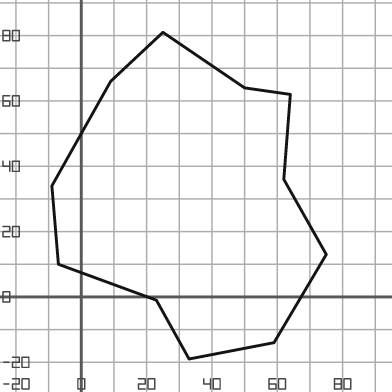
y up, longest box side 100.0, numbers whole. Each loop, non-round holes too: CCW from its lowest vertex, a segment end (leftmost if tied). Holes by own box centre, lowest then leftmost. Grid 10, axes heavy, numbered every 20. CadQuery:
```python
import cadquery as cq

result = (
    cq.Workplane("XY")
    .moveTo(33.0, -19.0)
    .lineTo(59.0, -14.0)
    .lineTo(75.0, 13.0)
    .lineTo(62.0, 36.0)
    .lineTo(64.0, 62.0)
    .lineTo(50.0, 64.0)
    .lineTo(25.0, 81.0)
    .lineTo(9.0, 66.0)
    .lineTo(-9.0, 34.0)
    .lineTo(-7.0, 10.0)
    .lineTo(23.0, -1.0)
    .close()
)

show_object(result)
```